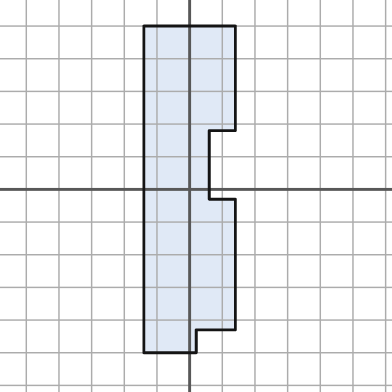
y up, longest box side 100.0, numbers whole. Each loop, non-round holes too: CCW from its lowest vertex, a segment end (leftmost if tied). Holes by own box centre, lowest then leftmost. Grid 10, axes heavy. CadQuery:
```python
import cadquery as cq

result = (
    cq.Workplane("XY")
    .moveTo(-14.0, -50.0)
    .lineTo(2.0, -50.0)
    .lineTo(2.0, -43.0)
    .lineTo(14.0, -43.0)
    .lineTo(14.0, -3.0)
    .lineTo(6.0, -3.0)
    .lineTo(6.0, 18.0)
    .lineTo(14.0, 18.0)
    .lineTo(14.0, 50.0)
    .lineTo(-14.0, 50.0)
    .close()
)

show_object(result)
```